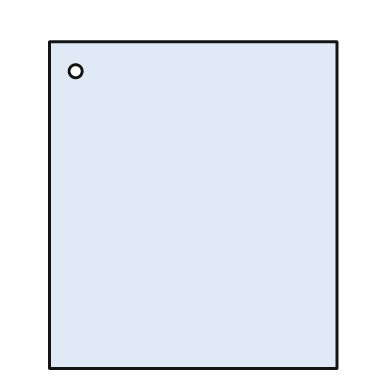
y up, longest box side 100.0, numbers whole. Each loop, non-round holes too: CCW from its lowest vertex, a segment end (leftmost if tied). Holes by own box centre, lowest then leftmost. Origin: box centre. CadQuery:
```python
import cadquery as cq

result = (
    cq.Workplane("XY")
    .moveTo(-44.0, -50.0)
    .lineTo(44.0, -50.0)
    .lineTo(44.0, 50.0)
    .lineTo(-44.0, 50.0)
    .close()
    .moveTo(-36.0, 41.0)
    .circle(2.0)
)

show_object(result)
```